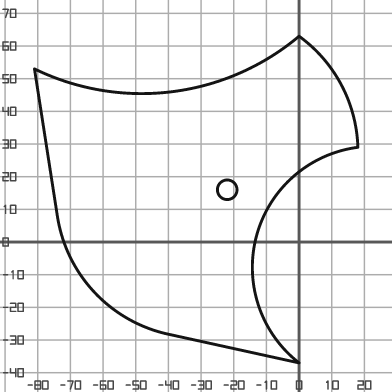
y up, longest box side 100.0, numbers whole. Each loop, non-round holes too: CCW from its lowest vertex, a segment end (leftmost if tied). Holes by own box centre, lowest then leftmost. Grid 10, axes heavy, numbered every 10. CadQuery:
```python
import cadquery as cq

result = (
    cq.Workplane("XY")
    .moveTo(0.0, -37.0)
    .threePointArc((-13.0, 2.0), (18.0, 29.0))
    .threePointArc((13.0, 48.0), (0.0, 63.0))
    .threePointArc((-39.0, 46.0), (-81.0, 53.0))
    .lineTo(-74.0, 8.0)
    .threePointArc((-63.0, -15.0), (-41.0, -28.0))
    .close()
    .moveTo(-22.0, 16.0)
    .circle(3.0)
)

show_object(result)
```